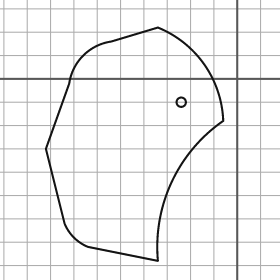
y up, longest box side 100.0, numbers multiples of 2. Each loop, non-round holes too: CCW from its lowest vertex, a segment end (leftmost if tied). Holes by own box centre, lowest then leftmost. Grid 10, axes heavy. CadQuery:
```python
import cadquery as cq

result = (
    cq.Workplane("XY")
    .moveTo(-34.0, -78.0)
    .threePointArc((-28.0, -44.0), (-6.0, -18.0))
    .threePointArc((-14.0, 6.0), (-34.0, 22.0))
    .lineTo(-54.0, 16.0)
    .threePointArc((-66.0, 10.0), (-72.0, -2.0))
    .lineTo(-82.0, -30.0)
    .lineTo(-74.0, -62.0)
    .threePointArc((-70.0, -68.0), (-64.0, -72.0))
    .close()
    .moveTo(-24.0, -10.0)
    .circle(2.0)
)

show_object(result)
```